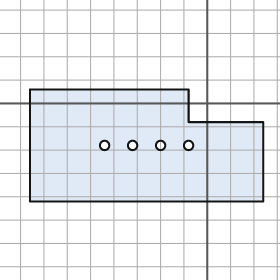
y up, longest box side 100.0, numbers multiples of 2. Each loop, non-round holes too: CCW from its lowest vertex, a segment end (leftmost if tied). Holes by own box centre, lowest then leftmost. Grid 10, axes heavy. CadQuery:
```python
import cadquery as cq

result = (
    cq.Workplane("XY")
    .moveTo(-76.0, -42.0)
    .lineTo(24.0, -42.0)
    .lineTo(24.0, -8.0)
    .lineTo(-8.0, -8.0)
    .lineTo(-8.0, 6.0)
    .lineTo(-76.0, 6.0)
    .close()
    .moveTo(-44.0, -18.0)
    .circle(2.0)
    .moveTo(-32.0, -18.0)
    .circle(2.0)
    .moveTo(-20.0, -18.0)
    .circle(2.0)
    .moveTo(-8.0, -18.0)
    .circle(2.0)
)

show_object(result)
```